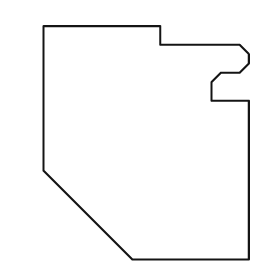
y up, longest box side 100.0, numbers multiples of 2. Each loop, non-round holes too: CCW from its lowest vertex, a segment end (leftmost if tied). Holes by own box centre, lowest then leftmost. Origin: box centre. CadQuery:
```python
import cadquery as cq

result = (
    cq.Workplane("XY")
    .moveTo(-6.0, -50.0)
    .lineTo(44.0, -50.0)
    .lineTo(44.0, 18.0)
    .lineTo(28.0, 18.0)
    .lineTo(28.0, 26.0)
    .lineTo(32.0, 30.0)
    .lineTo(40.0, 30.0)
    .lineTo(44.0, 34.0)
    .lineTo(44.0, 38.0)
    .lineTo(40.0, 42.0)
    .lineTo(6.0, 42.0)
    .lineTo(6.0, 50.0)
    .lineTo(-44.0, 50.0)
    .lineTo(-44.0, -12.0)
    .close()
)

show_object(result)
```